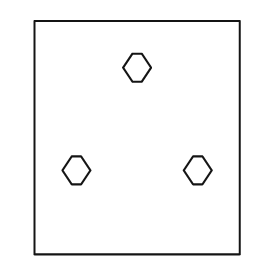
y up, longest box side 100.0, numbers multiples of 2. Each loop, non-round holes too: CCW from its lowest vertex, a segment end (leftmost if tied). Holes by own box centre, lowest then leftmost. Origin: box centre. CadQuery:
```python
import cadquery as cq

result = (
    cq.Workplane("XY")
    .moveTo(-44.0, -50.0)
    .lineTo(44.0, -50.0)
    .lineTo(44.0, 50.0)
    .lineTo(-44.0, 50.0)
    .close()
    .moveTo(-28.0, -20.0)
    .lineTo(-24.0, -20.0)
    .lineTo(-20.0, -14.0)
    .lineTo(-24.0, -8.0)
    .lineTo(-28.0, -8.0)
    .lineTo(-32.0, -14.0)
    .close()
    .moveTo(24.0, -20.0)
    .lineTo(28.0, -20.0)
    .lineTo(32.0, -14.0)
    .lineTo(28.0, -8.0)
    .lineTo(24.0, -8.0)
    .lineTo(20.0, -14.0)
    .close()
    .moveTo(-2.0, 24.0)
    .lineTo(2.0, 24.0)
    .lineTo(6.0, 30.0)
    .lineTo(2.0, 36.0)
    .lineTo(-2.0, 36.0)
    .lineTo(-6.0, 30.0)
    .close()
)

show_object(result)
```